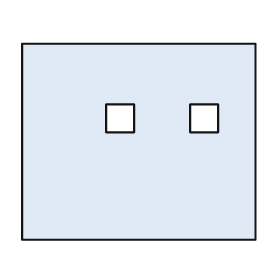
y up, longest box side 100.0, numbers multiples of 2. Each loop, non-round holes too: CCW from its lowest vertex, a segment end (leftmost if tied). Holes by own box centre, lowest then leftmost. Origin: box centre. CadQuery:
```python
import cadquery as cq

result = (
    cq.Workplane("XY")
    .moveTo(-50.0, -42.0)
    .lineTo(50.0, -42.0)
    .lineTo(50.0, 42.0)
    .lineTo(-50.0, 42.0)
    .close()
    .moveTo(-14.0, 4.0)
    .lineTo(-2.0, 4.0)
    .lineTo(-2.0, 16.0)
    .lineTo(-14.0, 16.0)
    .close()
    .moveTo(22.0, 4.0)
    .lineTo(34.0, 4.0)
    .lineTo(34.0, 16.0)
    .lineTo(22.0, 16.0)
    .close()
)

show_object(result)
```